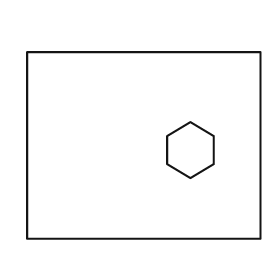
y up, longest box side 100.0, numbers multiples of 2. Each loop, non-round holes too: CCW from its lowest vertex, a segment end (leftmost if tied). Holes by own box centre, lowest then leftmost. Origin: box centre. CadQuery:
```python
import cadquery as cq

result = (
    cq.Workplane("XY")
    .moveTo(-50.0, -40.0)
    .lineTo(50.0, -40.0)
    .lineTo(50.0, 40.0)
    .lineTo(-50.0, 40.0)
    .close()
    .moveTo(20.0, -14.0)
    .lineTo(30.0, -8.0)
    .lineTo(30.0, 4.0)
    .lineTo(20.0, 10.0)
    .lineTo(10.0, 4.0)
    .lineTo(10.0, -8.0)
    .close()
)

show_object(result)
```